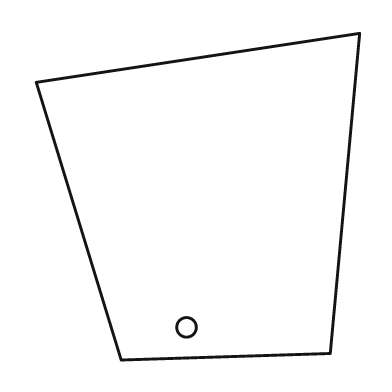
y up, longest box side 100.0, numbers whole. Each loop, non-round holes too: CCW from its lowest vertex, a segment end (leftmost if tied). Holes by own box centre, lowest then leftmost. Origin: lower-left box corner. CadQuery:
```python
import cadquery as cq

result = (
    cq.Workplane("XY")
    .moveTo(26.0, 0.0)
    .lineTo(90.0, 2.0)
    .lineTo(99.0, 100.0)
    .lineTo(0.0, 85.0)
    .close()
    .moveTo(46.0, 10.0)
    .circle(3.0)
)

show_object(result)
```